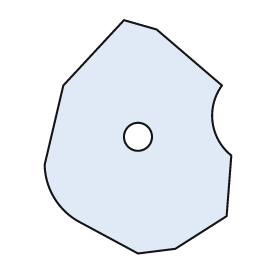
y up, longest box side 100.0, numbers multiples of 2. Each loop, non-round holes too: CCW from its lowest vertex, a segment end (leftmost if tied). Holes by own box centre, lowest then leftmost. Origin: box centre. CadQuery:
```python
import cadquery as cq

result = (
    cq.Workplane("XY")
    .moveTo(0.0, -50.0)
    .lineTo(16.0, -48.0)
    .lineTo(38.0, -34.0)
    .lineTo(40.0, -8.0)
    .threePointArc((32.0, 6.0), (36.0, 22.0))
    .lineTo(8.0, 46.0)
    .lineTo(-6.0, 50.0)
    .lineTo(-32.0, 22.0)
    .lineTo(-40.0, -12.0)
    .threePointArc((-36.0, -26.0), (-26.0, -36.0))
    .close()
    .moveTo(0.0, 0.0)
    .circle(6.0)
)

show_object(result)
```